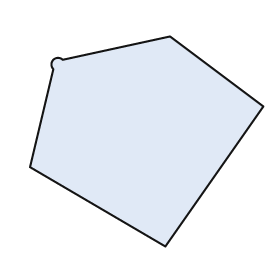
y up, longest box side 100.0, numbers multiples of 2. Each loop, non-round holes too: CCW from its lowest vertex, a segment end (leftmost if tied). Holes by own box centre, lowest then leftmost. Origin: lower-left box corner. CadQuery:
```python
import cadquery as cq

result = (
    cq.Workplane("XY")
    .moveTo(58.0, 0.0)
    .lineTo(100.0, 60.0)
    .lineTo(60.0, 90.0)
    .lineTo(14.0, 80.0)
    .threePointArc((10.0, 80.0), (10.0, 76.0))
    .lineTo(0.0, 34.0)
    .close()
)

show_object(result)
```